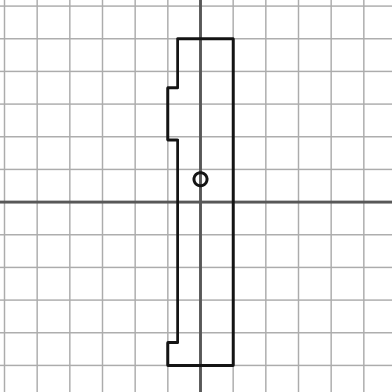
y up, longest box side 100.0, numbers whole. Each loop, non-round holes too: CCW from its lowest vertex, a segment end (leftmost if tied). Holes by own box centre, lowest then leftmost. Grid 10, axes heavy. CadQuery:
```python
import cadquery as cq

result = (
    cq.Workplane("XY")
    .moveTo(-10.0, -50.0)
    .lineTo(10.0, -50.0)
    .lineTo(10.0, 50.0)
    .lineTo(-7.0, 50.0)
    .lineTo(-7.0, 35.0)
    .lineTo(-10.0, 35.0)
    .lineTo(-10.0, 19.0)
    .lineTo(-7.0, 19.0)
    .lineTo(-7.0, -43.0)
    .lineTo(-10.0, -43.0)
    .close()
    .moveTo(0.0, 7.0)
    .circle(2.0)
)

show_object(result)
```